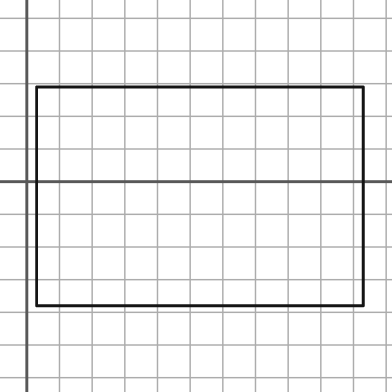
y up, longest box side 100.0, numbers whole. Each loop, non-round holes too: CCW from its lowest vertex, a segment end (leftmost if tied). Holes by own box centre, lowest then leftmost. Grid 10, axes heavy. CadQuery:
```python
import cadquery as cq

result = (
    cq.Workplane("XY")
    .moveTo(3.0, -38.0)
    .lineTo(103.0, -38.0)
    .lineTo(103.0, 29.0)
    .lineTo(3.0, 29.0)
    .close()
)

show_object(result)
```